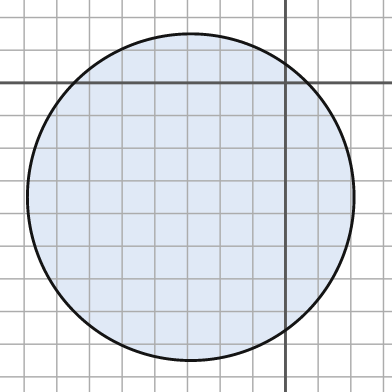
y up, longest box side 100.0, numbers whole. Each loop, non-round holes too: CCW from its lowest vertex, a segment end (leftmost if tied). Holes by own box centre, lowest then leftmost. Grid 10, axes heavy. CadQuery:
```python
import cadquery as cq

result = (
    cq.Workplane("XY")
    .moveTo(-29.0, -35.0)
    .circle(50.0)
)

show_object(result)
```